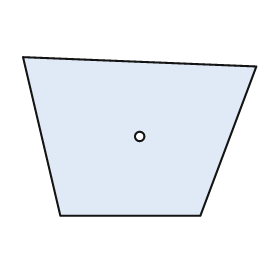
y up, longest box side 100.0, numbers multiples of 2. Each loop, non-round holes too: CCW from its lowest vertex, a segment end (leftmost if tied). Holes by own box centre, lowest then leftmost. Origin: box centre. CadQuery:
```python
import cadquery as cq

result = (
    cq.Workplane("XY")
    .moveTo(-34.0, -34.0)
    .lineTo(26.0, -34.0)
    .lineTo(50.0, 30.0)
    .lineTo(-50.0, 34.0)
    .close()
    .moveTo(0.0, 0.0)
    .circle(2.0)
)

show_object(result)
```